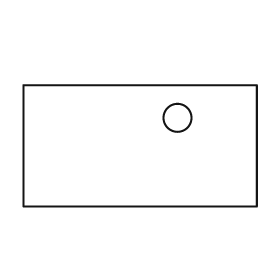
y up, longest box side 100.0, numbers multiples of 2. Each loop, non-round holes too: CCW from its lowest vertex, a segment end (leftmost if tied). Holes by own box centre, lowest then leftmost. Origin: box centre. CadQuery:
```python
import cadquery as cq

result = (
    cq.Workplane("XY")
    .moveTo(-50.0, -26.0)
    .lineTo(50.0, -26.0)
    .lineTo(50.0, 26.0)
    .lineTo(-50.0, 26.0)
    .close()
    .moveTo(16.0, 12.0)
    .circle(6.0)
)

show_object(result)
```